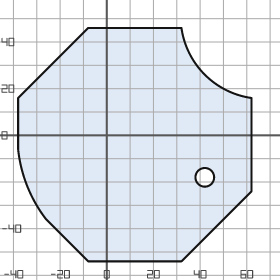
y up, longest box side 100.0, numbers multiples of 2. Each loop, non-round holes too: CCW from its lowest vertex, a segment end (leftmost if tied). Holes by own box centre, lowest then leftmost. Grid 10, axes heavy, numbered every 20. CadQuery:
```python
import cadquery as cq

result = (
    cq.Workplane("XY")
    .moveTo(-8.0, -54.0)
    .lineTo(32.0, -54.0)
    .lineTo(62.0, -24.0)
    .lineTo(62.0, 16.0)
    .threePointArc((42.0, 26.0), (32.0, 46.0))
    .lineTo(-8.0, 46.0)
    .lineTo(-38.0, 16.0)
    .lineTo(-38.0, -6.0)
    .threePointArc((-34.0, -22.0), (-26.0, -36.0))
    .close()
    .moveTo(42.0, -18.0)
    .circle(4.0)
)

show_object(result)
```